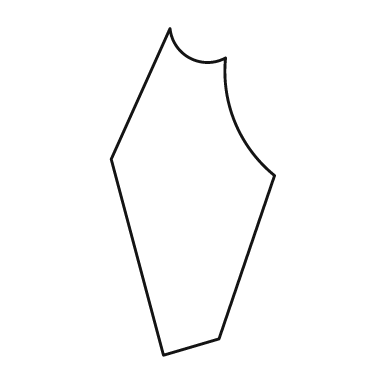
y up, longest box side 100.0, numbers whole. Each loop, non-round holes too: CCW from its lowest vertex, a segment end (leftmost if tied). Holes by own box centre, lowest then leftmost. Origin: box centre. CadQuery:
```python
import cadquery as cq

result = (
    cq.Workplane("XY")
    .moveTo(-9.0, -50.0)
    .lineTo(8.0, -45.0)
    .lineTo(25.0, 5.0)
    .threePointArc((13.0, 21.0), (10.0, 41.0))
    .threePointArc((-1.0, 41.0), (-7.0, 50.0))
    .lineTo(-25.0, 10.0)
    .close()
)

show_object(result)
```